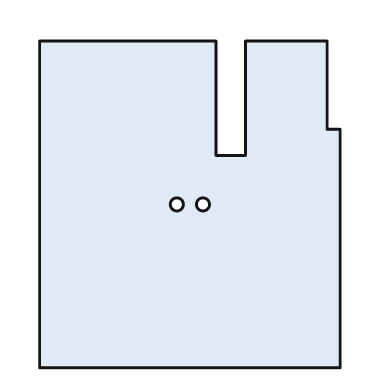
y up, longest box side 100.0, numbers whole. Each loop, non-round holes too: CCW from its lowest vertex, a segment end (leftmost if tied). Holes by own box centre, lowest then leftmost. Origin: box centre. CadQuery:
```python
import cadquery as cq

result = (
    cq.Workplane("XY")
    .moveTo(-46.0, -50.0)
    .lineTo(46.0, -50.0)
    .lineTo(46.0, 23.0)
    .lineTo(42.0, 23.0)
    .lineTo(42.0, 50.0)
    .lineTo(17.0, 50.0)
    .lineTo(17.0, 15.0)
    .lineTo(8.0, 15.0)
    .lineTo(8.0, 50.0)
    .lineTo(-46.0, 50.0)
    .close()
    .moveTo(-4.0, 0.0)
    .circle(2.0)
    .moveTo(4.0, 0.0)
    .circle(2.0)
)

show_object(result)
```